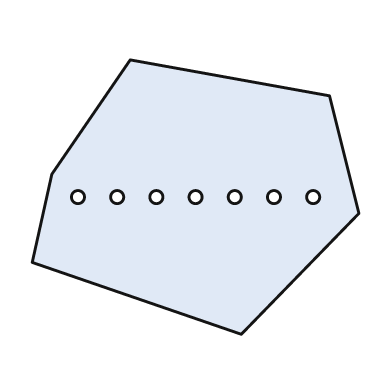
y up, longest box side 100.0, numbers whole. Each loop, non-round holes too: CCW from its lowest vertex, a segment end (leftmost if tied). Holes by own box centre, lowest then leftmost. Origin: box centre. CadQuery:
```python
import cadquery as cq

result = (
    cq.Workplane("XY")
    .moveTo(14.0, -42.0)
    .lineTo(50.0, -5.0)
    .lineTo(41.0, 31.0)
    .lineTo(-20.0, 42.0)
    .lineTo(-44.0, 7.0)
    .lineTo(-50.0, -20.0)
    .close()
    .moveTo(-36.0, 0.0)
    .circle(2.0)
    .moveTo(-24.0, 0.0)
    .circle(2.0)
    .moveTo(-12.0, 0.0)
    .circle(2.0)
    .moveTo(0.0, 0.0)
    .circle(2.0)
    .moveTo(12.0, 0.0)
    .circle(2.0)
    .moveTo(24.0, 0.0)
    .circle(2.0)
    .moveTo(36.0, 0.0)
    .circle(2.0)
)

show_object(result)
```